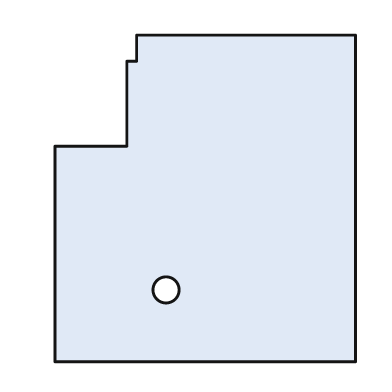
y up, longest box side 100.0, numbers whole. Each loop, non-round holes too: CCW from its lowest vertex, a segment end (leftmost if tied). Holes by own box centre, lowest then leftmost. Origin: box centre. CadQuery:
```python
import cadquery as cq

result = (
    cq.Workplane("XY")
    .moveTo(-46.0, -50.0)
    .lineTo(46.0, -50.0)
    .lineTo(46.0, 50.0)
    .lineTo(-21.0, 50.0)
    .lineTo(-21.0, 42.0)
    .lineTo(-24.0, 42.0)
    .lineTo(-24.0, 16.0)
    .lineTo(-46.0, 16.0)
    .close()
    .moveTo(-12.0, -28.0)
    .circle(4.0)
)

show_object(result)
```